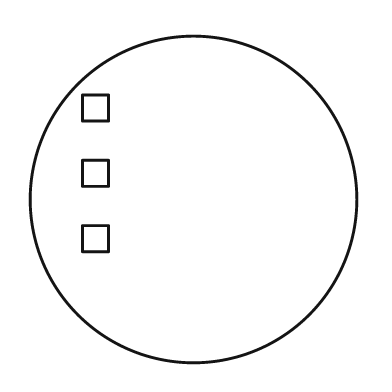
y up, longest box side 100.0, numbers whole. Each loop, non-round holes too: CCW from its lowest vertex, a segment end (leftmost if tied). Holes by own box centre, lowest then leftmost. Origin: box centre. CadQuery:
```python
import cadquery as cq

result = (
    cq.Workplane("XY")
    .moveTo(0.0, 0.0)
    .circle(50.0)
    .moveTo(-34.0, -16.0)
    .lineTo(-26.0, -16.0)
    .lineTo(-26.0, -8.0)
    .lineTo(-34.0, -8.0)
    .close()
    .moveTo(-34.0, 4.0)
    .lineTo(-26.0, 4.0)
    .lineTo(-26.0, 12.0)
    .lineTo(-34.0, 12.0)
    .close()
    .moveTo(-34.0, 24.0)
    .lineTo(-26.0, 24.0)
    .lineTo(-26.0, 32.0)
    .lineTo(-34.0, 32.0)
    .close()
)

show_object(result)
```